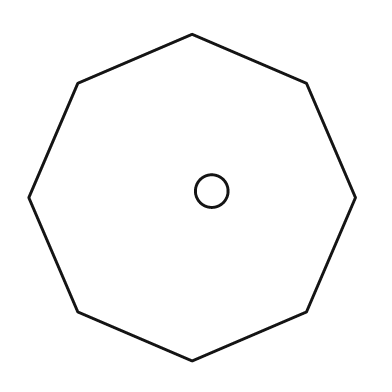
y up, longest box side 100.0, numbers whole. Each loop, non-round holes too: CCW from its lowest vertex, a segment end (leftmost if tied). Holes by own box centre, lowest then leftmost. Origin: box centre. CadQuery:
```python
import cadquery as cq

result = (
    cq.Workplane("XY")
    .moveTo(0.0, -50.0)
    .lineTo(35.0, -35.0)
    .lineTo(50.0, 0.0)
    .lineTo(35.0, 35.0)
    .lineTo(0.0, 50.0)
    .lineTo(-35.0, 35.0)
    .lineTo(-50.0, 0.0)
    .lineTo(-35.0, -35.0)
    .close()
    .moveTo(6.0, 2.0)
    .circle(5.0)
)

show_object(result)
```